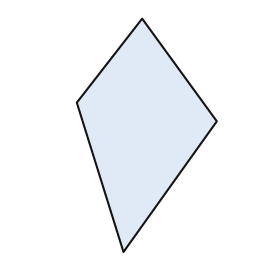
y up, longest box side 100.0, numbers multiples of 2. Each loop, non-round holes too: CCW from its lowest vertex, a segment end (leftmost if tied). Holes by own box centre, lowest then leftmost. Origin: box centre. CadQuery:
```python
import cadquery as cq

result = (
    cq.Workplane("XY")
    .moveTo(-10.0, -50.0)
    .lineTo(30.0, 6.0)
    .lineTo(-2.0, 50.0)
    .lineTo(-30.0, 14.0)
    .close()
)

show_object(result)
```